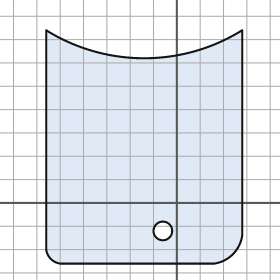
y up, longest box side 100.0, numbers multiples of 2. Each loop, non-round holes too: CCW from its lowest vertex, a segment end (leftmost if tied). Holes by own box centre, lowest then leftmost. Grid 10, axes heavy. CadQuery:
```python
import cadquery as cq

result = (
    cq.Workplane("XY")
    .moveTo(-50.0, -26.0)
    .lineTo(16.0, -26.0)
    .threePointArc((24.0, -22.0), (28.0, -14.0))
    .lineTo(28.0, 74.0)
    .threePointArc((-14.0, 62.0), (-56.0, 74.0))
    .lineTo(-56.0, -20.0)
    .threePointArc((-54.0, -24.0), (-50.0, -26.0))
    .close()
    .moveTo(-6.0, -12.0)
    .circle(4.0)
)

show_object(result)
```